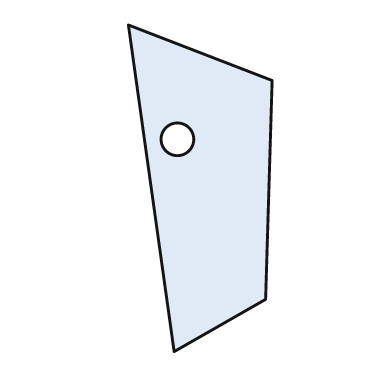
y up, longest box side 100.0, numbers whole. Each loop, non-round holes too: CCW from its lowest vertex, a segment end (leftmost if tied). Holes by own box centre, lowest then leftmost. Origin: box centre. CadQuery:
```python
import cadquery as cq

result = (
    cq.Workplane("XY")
    .moveTo(-8.0, -50.0)
    .lineTo(20.0, -34.0)
    .lineTo(22.0, 33.0)
    .lineTo(-22.0, 50.0)
    .close()
    .moveTo(-7.0, 15.0)
    .circle(5.0)
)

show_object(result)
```